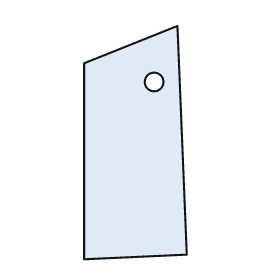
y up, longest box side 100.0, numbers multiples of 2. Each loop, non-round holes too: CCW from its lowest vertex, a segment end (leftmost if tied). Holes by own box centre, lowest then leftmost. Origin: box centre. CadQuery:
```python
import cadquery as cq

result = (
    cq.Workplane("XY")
    .moveTo(-22.0, -50.0)
    .lineTo(22.0, -48.0)
    .lineTo(18.0, 50.0)
    .lineTo(-22.0, 34.0)
    .close()
    .moveTo(8.0, 26.0)
    .circle(4.0)
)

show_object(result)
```